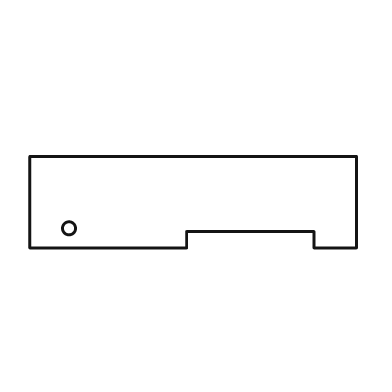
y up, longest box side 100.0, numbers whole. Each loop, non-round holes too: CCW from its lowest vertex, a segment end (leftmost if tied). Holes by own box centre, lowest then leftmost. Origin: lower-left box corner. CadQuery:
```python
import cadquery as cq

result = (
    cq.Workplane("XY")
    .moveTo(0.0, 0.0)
    .lineTo(48.0, 0.0)
    .lineTo(48.0, 5.0)
    .lineTo(87.0, 5.0)
    .lineTo(87.0, 0.0)
    .lineTo(100.0, 0.0)
    .lineTo(100.0, 28.0)
    .lineTo(0.0, 28.0)
    .close()
    .moveTo(12.0, 6.0)
    .circle(2.0)
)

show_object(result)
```